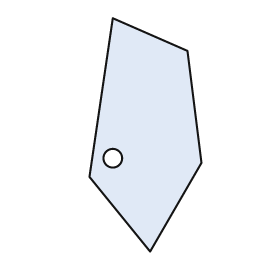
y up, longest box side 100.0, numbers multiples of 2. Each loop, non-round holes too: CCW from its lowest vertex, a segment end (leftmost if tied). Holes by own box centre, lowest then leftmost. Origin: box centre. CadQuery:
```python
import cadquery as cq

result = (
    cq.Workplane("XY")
    .moveTo(2.0, -50.0)
    .lineTo(24.0, -12.0)
    .lineTo(18.0, 36.0)
    .lineTo(-14.0, 50.0)
    .lineTo(-24.0, -18.0)
    .close()
    .moveTo(-14.0, -10.0)
    .circle(4.0)
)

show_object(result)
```